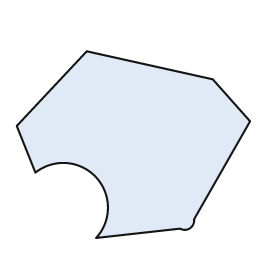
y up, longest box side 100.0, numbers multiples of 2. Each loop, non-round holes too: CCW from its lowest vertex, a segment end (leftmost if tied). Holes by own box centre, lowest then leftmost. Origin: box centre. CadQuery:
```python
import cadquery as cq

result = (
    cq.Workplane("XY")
    .moveTo(-16.0, -40.0)
    .lineTo(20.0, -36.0)
    .threePointArc((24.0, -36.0), (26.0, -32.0))
    .lineTo(50.0, 10.0)
    .lineTo(34.0, 28.0)
    .lineTo(-20.0, 40.0)
    .lineTo(-50.0, 8.0)
    .lineTo(-42.0, -12.0)
    .threePointArc((-16.0, -14.0), (-16.0, -40.0))
    .close()
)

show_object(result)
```